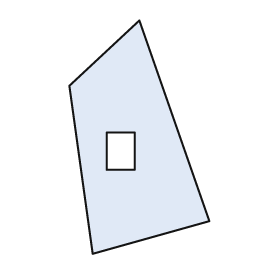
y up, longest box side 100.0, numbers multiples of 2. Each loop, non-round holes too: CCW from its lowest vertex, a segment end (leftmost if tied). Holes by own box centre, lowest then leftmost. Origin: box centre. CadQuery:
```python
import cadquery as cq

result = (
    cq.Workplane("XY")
    .moveTo(-20.0, -50.0)
    .lineTo(30.0, -36.0)
    .lineTo(0.0, 50.0)
    .lineTo(-30.0, 22.0)
    .close()
    .moveTo(-14.0, -14.0)
    .lineTo(-2.0, -14.0)
    .lineTo(-2.0, 2.0)
    .lineTo(-14.0, 2.0)
    .close()
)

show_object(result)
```